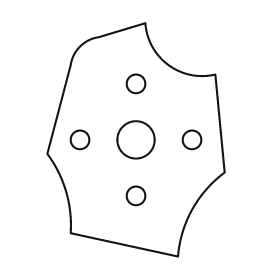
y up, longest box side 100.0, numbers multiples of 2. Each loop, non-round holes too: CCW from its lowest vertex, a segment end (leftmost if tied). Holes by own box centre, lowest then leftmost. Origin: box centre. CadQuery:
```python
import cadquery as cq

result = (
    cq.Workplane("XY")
    .moveTo(18.0, -50.0)
    .threePointArc((24.0, -30.0), (38.0, -14.0))
    .lineTo(34.0, 28.0)
    .threePointArc((14.0, 32.0), (4.0, 50.0))
    .lineTo(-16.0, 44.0)
    .threePointArc((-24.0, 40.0), (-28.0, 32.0))
    .lineTo(-38.0, -6.0)
    .threePointArc((-30.0, -22.0), (-28.0, -40.0))
    .close()
    .moveTo(0.0, -24.0)
    .circle(4.0)
    .moveTo(-24.0, 0.0)
    .circle(4.0)
    .moveTo(0.0, 0.0)
    .circle(8.0)
    .moveTo(24.0, 0.0)
    .circle(4.0)
    .moveTo(0.0, 24.0)
    .circle(4.0)
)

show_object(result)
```